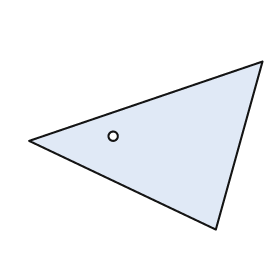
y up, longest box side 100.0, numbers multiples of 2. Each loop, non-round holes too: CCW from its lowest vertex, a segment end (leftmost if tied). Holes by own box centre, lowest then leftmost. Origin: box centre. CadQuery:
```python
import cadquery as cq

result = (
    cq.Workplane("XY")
    .moveTo(30.0, -36.0)
    .lineTo(50.0, 36.0)
    .lineTo(-50.0, 2.0)
    .close()
    .moveTo(-14.0, 4.0)
    .circle(2.0)
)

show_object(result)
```